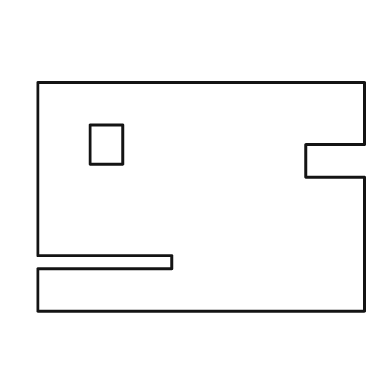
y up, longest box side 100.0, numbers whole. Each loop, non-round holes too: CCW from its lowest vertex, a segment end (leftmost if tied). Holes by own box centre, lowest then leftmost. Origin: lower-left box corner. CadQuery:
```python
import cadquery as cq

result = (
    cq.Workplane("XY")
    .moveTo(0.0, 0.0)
    .lineTo(100.0, 0.0)
    .lineTo(100.0, 41.0)
    .lineTo(82.0, 41.0)
    .lineTo(82.0, 51.0)
    .lineTo(100.0, 51.0)
    .lineTo(100.0, 70.0)
    .lineTo(0.0, 70.0)
    .lineTo(0.0, 17.0)
    .lineTo(41.0, 17.0)
    .lineTo(41.0, 13.0)
    .lineTo(0.0, 13.0)
    .close()
    .moveTo(16.0, 45.0)
    .lineTo(26.0, 45.0)
    .lineTo(26.0, 57.0)
    .lineTo(16.0, 57.0)
    .close()
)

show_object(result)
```